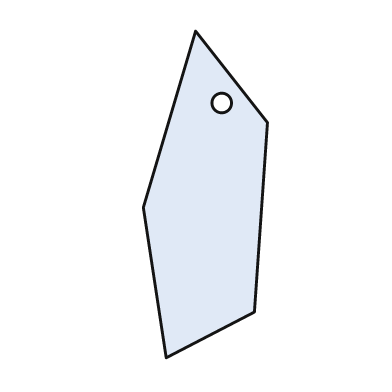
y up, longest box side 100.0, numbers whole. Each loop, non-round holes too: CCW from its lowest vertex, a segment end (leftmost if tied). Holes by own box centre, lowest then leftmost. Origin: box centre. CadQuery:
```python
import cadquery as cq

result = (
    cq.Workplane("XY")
    .moveTo(-12.0, -50.0)
    .lineTo(15.0, -36.0)
    .lineTo(19.0, 22.0)
    .lineTo(-3.0, 50.0)
    .lineTo(-19.0, -4.0)
    .close()
    .moveTo(5.0, 28.0)
    .circle(3.0)
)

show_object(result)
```